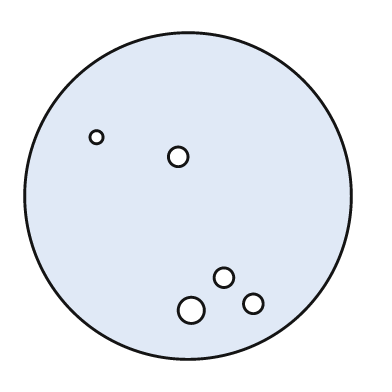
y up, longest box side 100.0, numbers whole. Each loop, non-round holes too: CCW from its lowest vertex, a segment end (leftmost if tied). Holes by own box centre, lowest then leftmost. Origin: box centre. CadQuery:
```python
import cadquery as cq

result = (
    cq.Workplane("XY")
    .moveTo(0.0, 0.0)
    .circle(50.0)
    .moveTo(1.0, -35.0)
    .circle(4.0)
    .moveTo(20.0, -33.0)
    .circle(3.0)
    .moveTo(11.0, -25.0)
    .circle(3.0)
    .moveTo(-3.0, 12.0)
    .circle(3.0)
    .moveTo(-28.0, 18.0)
    .circle(2.0)
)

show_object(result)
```